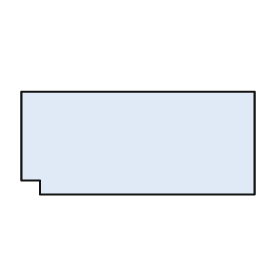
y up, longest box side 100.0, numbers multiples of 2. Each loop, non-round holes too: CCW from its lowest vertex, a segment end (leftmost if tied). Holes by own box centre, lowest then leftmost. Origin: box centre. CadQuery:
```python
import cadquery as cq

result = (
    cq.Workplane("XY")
    .moveTo(-42.0, -22.0)
    .lineTo(50.0, -22.0)
    .lineTo(50.0, 22.0)
    .lineTo(-50.0, 22.0)
    .lineTo(-50.0, -16.0)
    .lineTo(-42.0, -16.0)
    .close()
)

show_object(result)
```